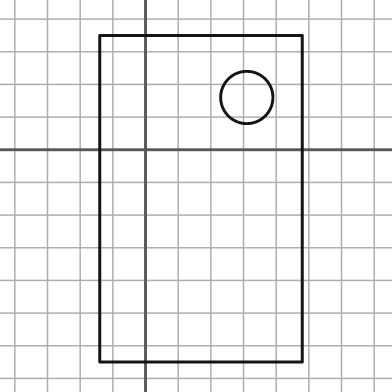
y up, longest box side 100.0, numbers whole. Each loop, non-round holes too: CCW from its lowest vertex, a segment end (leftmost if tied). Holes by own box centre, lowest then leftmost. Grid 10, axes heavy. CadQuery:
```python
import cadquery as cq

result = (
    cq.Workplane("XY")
    .moveTo(-14.0, -65.0)
    .lineTo(48.0, -65.0)
    .lineTo(48.0, 35.0)
    .lineTo(-14.0, 35.0)
    .close()
    .moveTo(31.0, 16.0)
    .circle(8.0)
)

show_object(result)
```